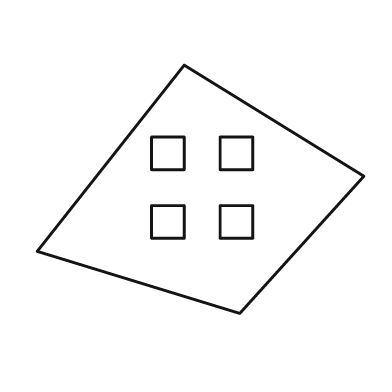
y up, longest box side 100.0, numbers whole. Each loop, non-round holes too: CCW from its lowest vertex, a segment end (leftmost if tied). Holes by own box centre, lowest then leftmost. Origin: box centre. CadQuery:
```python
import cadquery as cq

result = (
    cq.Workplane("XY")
    .moveTo(12.0, -38.0)
    .lineTo(50.0, 4.0)
    .lineTo(-5.0, 38.0)
    .lineTo(-50.0, -19.0)
    .close()
    .moveTo(-15.0, -15.0)
    .lineTo(-5.0, -15.0)
    .lineTo(-5.0, -5.0)
    .lineTo(-15.0, -5.0)
    .close()
    .moveTo(6.0, -15.0)
    .lineTo(16.0, -15.0)
    .lineTo(16.0, -5.0)
    .lineTo(6.0, -5.0)
    .close()
    .moveTo(-15.0, 6.0)
    .lineTo(-5.0, 6.0)
    .lineTo(-5.0, 16.0)
    .lineTo(-15.0, 16.0)
    .close()
    .moveTo(6.0, 6.0)
    .lineTo(16.0, 6.0)
    .lineTo(16.0, 16.0)
    .lineTo(6.0, 16.0)
    .close()
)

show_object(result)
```